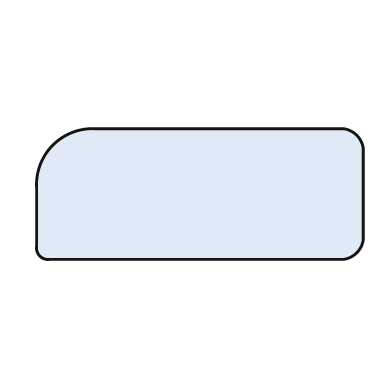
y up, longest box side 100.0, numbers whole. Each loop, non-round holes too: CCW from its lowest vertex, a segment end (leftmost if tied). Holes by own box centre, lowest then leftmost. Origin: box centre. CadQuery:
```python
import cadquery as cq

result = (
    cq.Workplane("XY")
    .moveTo(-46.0, -20.0)
    .lineTo(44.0, -20.0)
    .threePointArc((48.0, -18.0), (50.0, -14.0))
    .lineTo(50.0, 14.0)
    .threePointArc((48.0, 18.0), (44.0, 20.0))
    .lineTo(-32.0, 20.0)
    .threePointArc((-45.0, 15.0), (-50.0, 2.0))
    .lineTo(-50.0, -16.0)
    .threePointArc((-49.0, -19.0), (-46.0, -20.0))
    .close()
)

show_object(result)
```